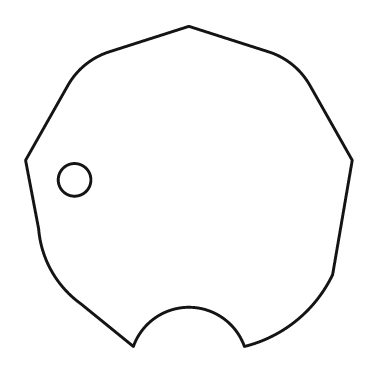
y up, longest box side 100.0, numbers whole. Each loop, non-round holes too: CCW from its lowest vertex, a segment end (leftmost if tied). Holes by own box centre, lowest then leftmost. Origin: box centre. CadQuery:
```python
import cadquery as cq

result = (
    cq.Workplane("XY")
    .moveTo(-17.0, -49.0)
    .threePointArc((0.0, -37.0), (17.0, -49.0))
    .threePointArc((33.0, -41.0), (44.0, -27.0))
    .lineTo(50.0, 8.0)
    .lineTo(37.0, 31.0)
    .threePointArc((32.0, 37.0), (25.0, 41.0))
    .lineTo(0.0, 49.0)
    .lineTo(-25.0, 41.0)
    .threePointArc((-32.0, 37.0), (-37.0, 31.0))
    .lineTo(-50.0, 8.0)
    .lineTo(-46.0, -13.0)
    .threePointArc((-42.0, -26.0), (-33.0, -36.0))
    .close()
    .moveTo(-35.0, 2.0)
    .circle(5.0)
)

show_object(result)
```